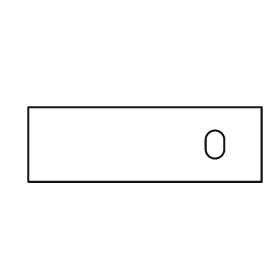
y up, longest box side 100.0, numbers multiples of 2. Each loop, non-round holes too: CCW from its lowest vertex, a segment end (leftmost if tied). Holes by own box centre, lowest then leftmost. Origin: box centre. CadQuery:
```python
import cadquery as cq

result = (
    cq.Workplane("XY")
    .moveTo(-50.0, -16.0)
    .lineTo(50.0, -16.0)
    .lineTo(50.0, 16.0)
    .lineTo(-50.0, 16.0)
    .close()
    .moveTo(26.0, -2.0)
    .threePointArc((30.0, -6.0), (34.0, -2.0))
    .lineTo(34.0, 2.0)
    .threePointArc((30.0, 6.0), (26.0, 2.0))
    .close()
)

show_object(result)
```